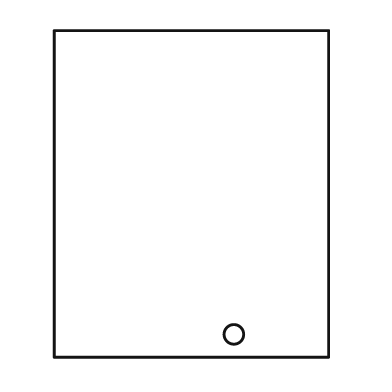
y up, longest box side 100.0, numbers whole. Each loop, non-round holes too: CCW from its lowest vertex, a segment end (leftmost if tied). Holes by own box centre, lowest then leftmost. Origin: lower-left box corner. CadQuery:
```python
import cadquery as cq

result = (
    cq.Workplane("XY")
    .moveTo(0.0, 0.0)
    .lineTo(84.0, 0.0)
    .lineTo(84.0, 100.0)
    .lineTo(0.0, 100.0)
    .close()
    .moveTo(55.0, 7.0)
    .circle(3.0)
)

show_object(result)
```